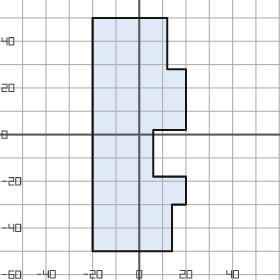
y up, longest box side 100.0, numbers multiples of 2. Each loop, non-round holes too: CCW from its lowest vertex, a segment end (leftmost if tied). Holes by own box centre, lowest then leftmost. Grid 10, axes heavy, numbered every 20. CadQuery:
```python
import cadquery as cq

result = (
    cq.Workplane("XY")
    .moveTo(-20.0, -50.0)
    .lineTo(14.0, -50.0)
    .lineTo(14.0, -30.0)
    .lineTo(20.0, -30.0)
    .lineTo(20.0, -18.0)
    .lineTo(6.0, -18.0)
    .lineTo(6.0, 2.0)
    .lineTo(20.0, 2.0)
    .lineTo(20.0, 28.0)
    .lineTo(12.0, 28.0)
    .lineTo(12.0, 50.0)
    .lineTo(-20.0, 50.0)
    .close()
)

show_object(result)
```